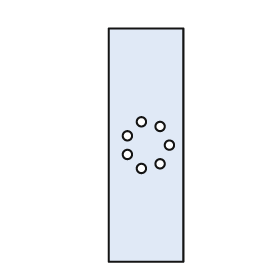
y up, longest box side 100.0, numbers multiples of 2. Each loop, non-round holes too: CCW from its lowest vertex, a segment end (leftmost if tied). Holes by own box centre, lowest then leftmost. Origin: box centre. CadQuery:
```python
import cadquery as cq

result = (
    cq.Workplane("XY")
    .moveTo(-16.0, -50.0)
    .lineTo(16.0, -50.0)
    .lineTo(16.0, 50.0)
    .lineTo(-16.0, 50.0)
    .close()
    .moveTo(-2.0, -10.0)
    .circle(2.0)
    .moveTo(6.0, -8.0)
    .circle(2.0)
    .moveTo(-8.0, -4.0)
    .circle(2.0)
    .moveTo(10.0, 0.0)
    .circle(2.0)
    .moveTo(-8.0, 4.0)
    .circle(2.0)
    .moveTo(6.0, 8.0)
    .circle(2.0)
    .moveTo(-2.0, 10.0)
    .circle(2.0)
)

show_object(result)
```